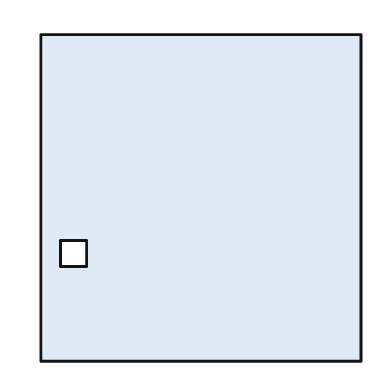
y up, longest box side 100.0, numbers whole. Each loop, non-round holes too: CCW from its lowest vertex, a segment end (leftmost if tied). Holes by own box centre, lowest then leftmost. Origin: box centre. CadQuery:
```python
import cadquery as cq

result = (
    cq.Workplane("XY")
    .moveTo(-49.0, -50.0)
    .lineTo(49.0, -50.0)
    .lineTo(49.0, 50.0)
    .lineTo(-49.0, 50.0)
    .close()
    .moveTo(-43.0, -21.0)
    .lineTo(-35.0, -21.0)
    .lineTo(-35.0, -13.0)
    .lineTo(-43.0, -13.0)
    .close()
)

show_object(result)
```